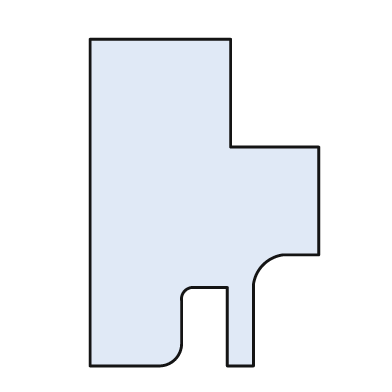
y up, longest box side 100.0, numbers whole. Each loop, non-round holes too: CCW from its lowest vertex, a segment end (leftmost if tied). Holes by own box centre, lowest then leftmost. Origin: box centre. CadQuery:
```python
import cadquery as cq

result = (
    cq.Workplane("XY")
    .moveTo(-35.0, -50.0)
    .lineTo(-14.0, -50.0)
    .threePointArc((-9.0, -48.0), (-7.0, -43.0))
    .lineTo(-7.0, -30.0)
    .threePointArc((-6.0, -27.0), (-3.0, -26.0))
    .lineTo(7.0, -26.0)
    .lineTo(7.0, -50.0)
    .lineTo(15.0, -50.0)
    .lineTo(15.0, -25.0)
    .threePointArc((18.0, -19.0), (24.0, -16.0))
    .lineTo(35.0, -16.0)
    .lineTo(35.0, 17.0)
    .lineTo(8.0, 17.0)
    .lineTo(8.0, 50.0)
    .lineTo(-35.0, 50.0)
    .close()
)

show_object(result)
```